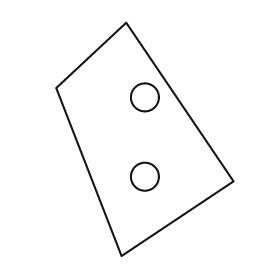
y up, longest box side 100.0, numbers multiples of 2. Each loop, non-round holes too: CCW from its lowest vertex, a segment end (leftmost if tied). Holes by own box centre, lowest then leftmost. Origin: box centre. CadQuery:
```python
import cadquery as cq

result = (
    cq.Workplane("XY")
    .moveTo(-10.0, -50.0)
    .lineTo(38.0, -18.0)
    .lineTo(-8.0, 50.0)
    .lineTo(-38.0, 22.0)
    .close()
    .moveTo(0.0, -16.0)
    .circle(6.0)
    .moveTo(0.0, 18.0)
    .circle(6.0)
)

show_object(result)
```